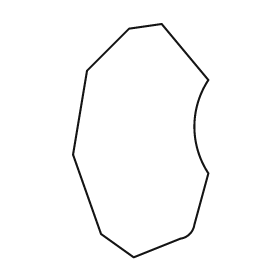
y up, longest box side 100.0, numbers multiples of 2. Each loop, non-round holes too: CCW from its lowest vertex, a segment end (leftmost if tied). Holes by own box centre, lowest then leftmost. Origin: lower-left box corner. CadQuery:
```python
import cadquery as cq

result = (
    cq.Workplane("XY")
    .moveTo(26.0, 0.0)
    .lineTo(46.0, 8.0)
    .threePointArc((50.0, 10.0), (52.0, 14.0))
    .lineTo(58.0, 36.0)
    .threePointArc((52.0, 56.0), (58.0, 76.0))
    .lineTo(38.0, 100.0)
    .lineTo(24.0, 98.0)
    .lineTo(6.0, 80.0)
    .lineTo(0.0, 44.0)
    .lineTo(12.0, 10.0)
    .close()
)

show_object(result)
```